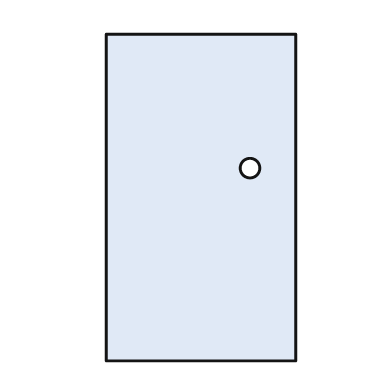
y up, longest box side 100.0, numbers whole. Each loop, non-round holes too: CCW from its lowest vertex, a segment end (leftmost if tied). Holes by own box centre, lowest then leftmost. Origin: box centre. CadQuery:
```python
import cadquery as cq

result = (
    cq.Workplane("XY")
    .moveTo(-29.0, -50.0)
    .lineTo(29.0, -50.0)
    .lineTo(29.0, 50.0)
    .lineTo(-29.0, 50.0)
    .close()
    .moveTo(15.0, 9.0)
    .circle(3.0)
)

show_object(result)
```